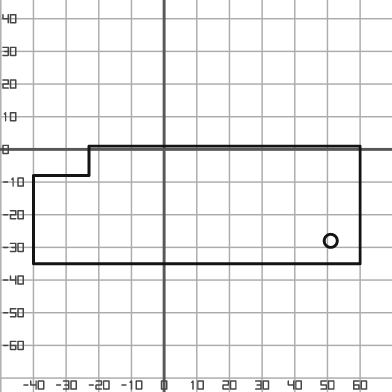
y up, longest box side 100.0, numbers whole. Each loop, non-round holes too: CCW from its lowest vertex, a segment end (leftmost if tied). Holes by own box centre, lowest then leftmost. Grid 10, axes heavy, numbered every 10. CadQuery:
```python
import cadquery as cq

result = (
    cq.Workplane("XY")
    .moveTo(-40.0, -35.0)
    .lineTo(60.0, -35.0)
    .lineTo(60.0, 1.0)
    .lineTo(-23.0, 1.0)
    .lineTo(-23.0, -8.0)
    .lineTo(-40.0, -8.0)
    .close()
    .moveTo(51.0, -28.0)
    .circle(2.0)
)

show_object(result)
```